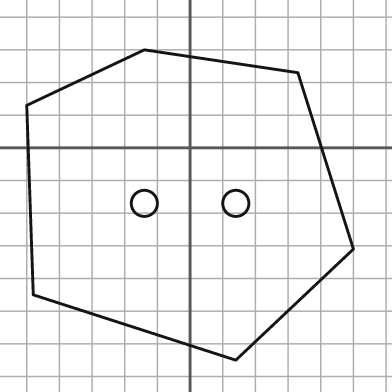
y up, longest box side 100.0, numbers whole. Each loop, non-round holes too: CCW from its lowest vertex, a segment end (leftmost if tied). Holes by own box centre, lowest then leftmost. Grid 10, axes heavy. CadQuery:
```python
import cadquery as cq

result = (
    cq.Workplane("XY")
    .moveTo(14.0, -65.0)
    .lineTo(50.0, -31.0)
    .lineTo(33.0, 23.0)
    .lineTo(-14.0, 30.0)
    .lineTo(-50.0, 13.0)
    .lineTo(-48.0, -45.0)
    .close()
    .moveTo(-14.0, -17.0)
    .circle(4.0)
    .moveTo(14.0, -17.0)
    .circle(4.0)
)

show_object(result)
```